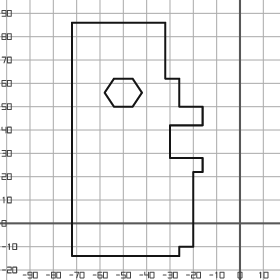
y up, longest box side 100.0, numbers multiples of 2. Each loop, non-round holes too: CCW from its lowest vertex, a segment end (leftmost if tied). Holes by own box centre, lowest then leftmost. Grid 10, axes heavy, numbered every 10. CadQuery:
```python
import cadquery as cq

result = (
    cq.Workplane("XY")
    .moveTo(-72.0, -14.0)
    .lineTo(-26.0, -14.0)
    .lineTo(-26.0, -10.0)
    .lineTo(-20.0, -10.0)
    .lineTo(-20.0, 22.0)
    .lineTo(-16.0, 22.0)
    .lineTo(-16.0, 28.0)
    .lineTo(-30.0, 28.0)
    .lineTo(-30.0, 42.0)
    .lineTo(-16.0, 42.0)
    .lineTo(-16.0, 50.0)
    .lineTo(-26.0, 50.0)
    .lineTo(-26.0, 62.0)
    .lineTo(-32.0, 62.0)
    .lineTo(-32.0, 86.0)
    .lineTo(-72.0, 86.0)
    .close()
    .moveTo(-54.0, 50.0)
    .lineTo(-46.0, 50.0)
    .lineTo(-42.0, 56.0)
    .lineTo(-46.0, 62.0)
    .lineTo(-54.0, 62.0)
    .lineTo(-58.0, 56.0)
    .close()
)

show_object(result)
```